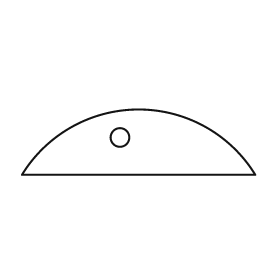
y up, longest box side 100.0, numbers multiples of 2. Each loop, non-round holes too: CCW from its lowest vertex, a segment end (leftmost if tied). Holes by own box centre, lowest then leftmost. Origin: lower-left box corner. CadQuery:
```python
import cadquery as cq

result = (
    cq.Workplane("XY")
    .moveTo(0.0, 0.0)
    .lineTo(100.0, 0.0)
    .threePointArc((50.0, 28.0), (0.0, 0.0))
    .close()
    .moveTo(42.0, 16.0)
    .circle(4.0)
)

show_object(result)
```